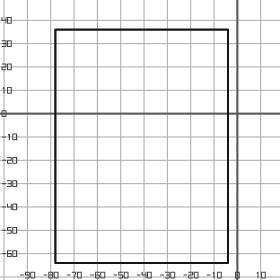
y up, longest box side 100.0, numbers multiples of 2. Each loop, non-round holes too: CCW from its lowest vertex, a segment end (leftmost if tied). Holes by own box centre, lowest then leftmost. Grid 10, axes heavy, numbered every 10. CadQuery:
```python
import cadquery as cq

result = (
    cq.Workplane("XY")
    .moveTo(-78.0, -64.0)
    .lineTo(-4.0, -64.0)
    .lineTo(-4.0, 36.0)
    .lineTo(-78.0, 36.0)
    .close()
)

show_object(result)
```